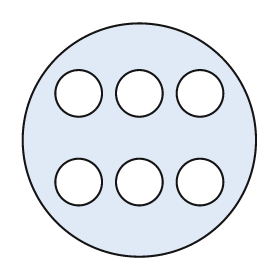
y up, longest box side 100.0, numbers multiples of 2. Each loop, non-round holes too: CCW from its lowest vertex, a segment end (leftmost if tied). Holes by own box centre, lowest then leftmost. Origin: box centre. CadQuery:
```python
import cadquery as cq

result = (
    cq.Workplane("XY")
    .moveTo(0.0, 0.0)
    .circle(50.0)
    .moveTo(-26.0, -18.0)
    .circle(10.0)
    .moveTo(0.0, -18.0)
    .circle(10.0)
    .moveTo(26.0, -18.0)
    .circle(10.0)
    .moveTo(-26.0, 20.0)
    .circle(10.0)
    .moveTo(0.0, 20.0)
    .circle(10.0)
    .moveTo(26.0, 20.0)
    .circle(10.0)
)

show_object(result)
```